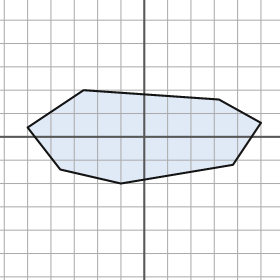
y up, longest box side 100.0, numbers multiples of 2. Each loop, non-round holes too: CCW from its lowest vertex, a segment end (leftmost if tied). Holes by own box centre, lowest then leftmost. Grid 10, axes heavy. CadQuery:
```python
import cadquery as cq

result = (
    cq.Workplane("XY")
    .moveTo(-10.0, -20.0)
    .lineTo(38.0, -12.0)
    .lineTo(50.0, 6.0)
    .lineTo(32.0, 16.0)
    .lineTo(-26.0, 20.0)
    .lineTo(-50.0, 4.0)
    .lineTo(-36.0, -14.0)
    .close()
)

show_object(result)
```